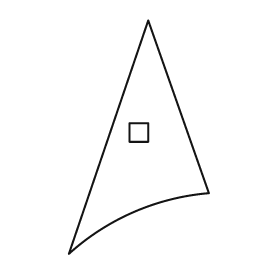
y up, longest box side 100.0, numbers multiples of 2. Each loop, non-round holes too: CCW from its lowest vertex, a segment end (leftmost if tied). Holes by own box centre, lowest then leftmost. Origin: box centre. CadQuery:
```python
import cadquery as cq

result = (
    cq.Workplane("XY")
    .moveTo(-30.0, -50.0)
    .threePointArc((-2.0, -32.0), (30.0, -24.0))
    .lineTo(4.0, 50.0)
    .close()
    .moveTo(-4.0, -2.0)
    .lineTo(4.0, -2.0)
    .lineTo(4.0, 6.0)
    .lineTo(-4.0, 6.0)
    .close()
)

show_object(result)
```